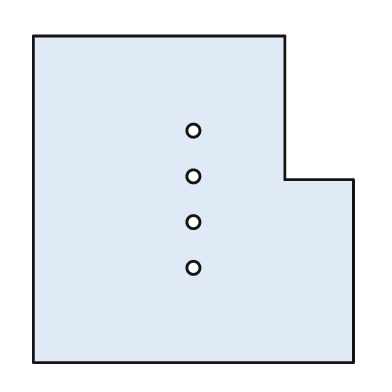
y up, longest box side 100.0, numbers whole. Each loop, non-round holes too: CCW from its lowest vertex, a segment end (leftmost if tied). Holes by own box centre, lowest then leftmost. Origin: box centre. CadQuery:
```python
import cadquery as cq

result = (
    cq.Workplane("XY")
    .moveTo(-49.0, -50.0)
    .lineTo(49.0, -50.0)
    .lineTo(49.0, 6.0)
    .lineTo(28.0, 6.0)
    .lineTo(28.0, 50.0)
    .lineTo(-49.0, 50.0)
    .close()
    .moveTo(0.0, -21.0)
    .circle(2.0)
    .moveTo(0.0, -7.0)
    .circle(2.0)
    .moveTo(0.0, 7.0)
    .circle(2.0)
    .moveTo(0.0, 21.0)
    .circle(2.0)
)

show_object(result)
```